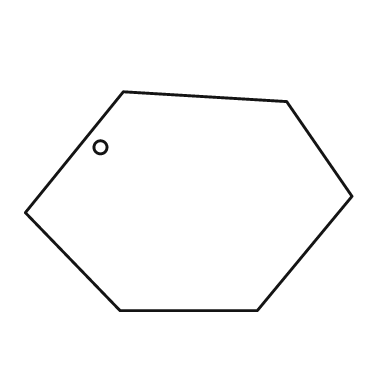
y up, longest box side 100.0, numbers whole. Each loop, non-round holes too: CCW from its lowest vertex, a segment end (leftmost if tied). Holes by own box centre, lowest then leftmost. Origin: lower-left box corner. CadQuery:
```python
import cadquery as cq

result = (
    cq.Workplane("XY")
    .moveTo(29.0, 0.0)
    .lineTo(71.0, 0.0)
    .lineTo(100.0, 35.0)
    .lineTo(80.0, 64.0)
    .lineTo(30.0, 67.0)
    .lineTo(0.0, 30.0)
    .close()
    .moveTo(23.0, 50.0)
    .circle(2.0)
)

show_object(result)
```